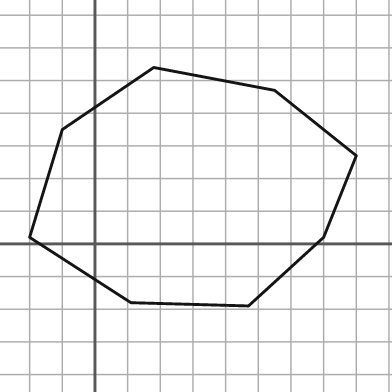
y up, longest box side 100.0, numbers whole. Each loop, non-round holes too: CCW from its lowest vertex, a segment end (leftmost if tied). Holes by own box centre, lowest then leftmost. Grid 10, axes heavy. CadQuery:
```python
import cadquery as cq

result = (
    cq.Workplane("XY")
    .moveTo(47.0, -19.0)
    .lineTo(70.0, 2.0)
    .lineTo(80.0, 27.0)
    .lineTo(55.0, 47.0)
    .lineTo(18.0, 54.0)
    .lineTo(-10.0, 35.0)
    .lineTo(-20.0, 2.0)
    .lineTo(11.0, -18.0)
    .close()
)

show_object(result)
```